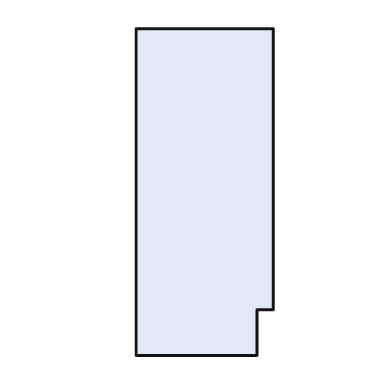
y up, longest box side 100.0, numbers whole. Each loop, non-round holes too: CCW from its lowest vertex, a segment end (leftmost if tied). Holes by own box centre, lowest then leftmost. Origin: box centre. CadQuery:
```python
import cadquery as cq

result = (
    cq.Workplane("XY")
    .moveTo(-21.0, -50.0)
    .lineTo(16.0, -50.0)
    .lineTo(16.0, -36.0)
    .lineTo(21.0, -36.0)
    .lineTo(21.0, 50.0)
    .lineTo(-21.0, 50.0)
    .close()
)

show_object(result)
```